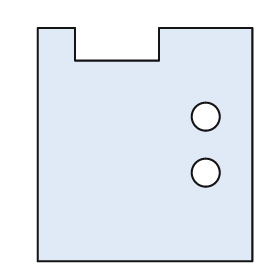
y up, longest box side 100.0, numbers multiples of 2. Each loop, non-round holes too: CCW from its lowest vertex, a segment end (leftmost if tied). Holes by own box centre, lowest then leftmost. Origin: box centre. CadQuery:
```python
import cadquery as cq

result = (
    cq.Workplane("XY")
    .moveTo(-46.0, -50.0)
    .lineTo(46.0, -50.0)
    .lineTo(46.0, 50.0)
    .lineTo(6.0, 50.0)
    .lineTo(6.0, 36.0)
    .lineTo(-30.0, 36.0)
    .lineTo(-30.0, 50.0)
    .lineTo(-46.0, 50.0)
    .close()
    .moveTo(26.0, -12.0)
    .circle(6.0)
    .moveTo(26.0, 12.0)
    .circle(6.0)
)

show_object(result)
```